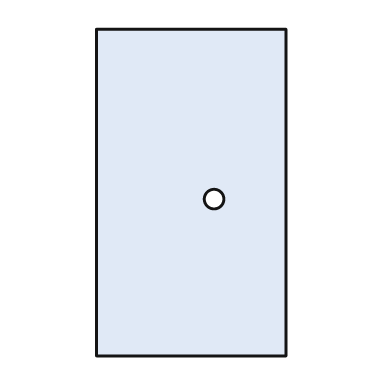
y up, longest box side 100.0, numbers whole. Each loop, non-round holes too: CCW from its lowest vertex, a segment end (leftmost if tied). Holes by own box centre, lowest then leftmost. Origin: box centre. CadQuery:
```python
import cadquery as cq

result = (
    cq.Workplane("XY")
    .moveTo(-29.0, -50.0)
    .lineTo(29.0, -50.0)
    .lineTo(29.0, 50.0)
    .lineTo(-29.0, 50.0)
    .close()
    .moveTo(7.0, -2.0)
    .circle(3.0)
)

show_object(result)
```